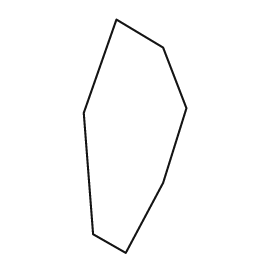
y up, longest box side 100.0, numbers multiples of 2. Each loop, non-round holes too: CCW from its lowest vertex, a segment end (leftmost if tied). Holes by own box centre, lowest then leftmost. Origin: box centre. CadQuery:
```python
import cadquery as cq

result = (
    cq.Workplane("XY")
    .moveTo(-4.0, -50.0)
    .lineTo(12.0, -20.0)
    .lineTo(22.0, 12.0)
    .lineTo(12.0, 38.0)
    .lineTo(-8.0, 50.0)
    .lineTo(-22.0, 10.0)
    .lineTo(-18.0, -42.0)
    .close()
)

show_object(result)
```